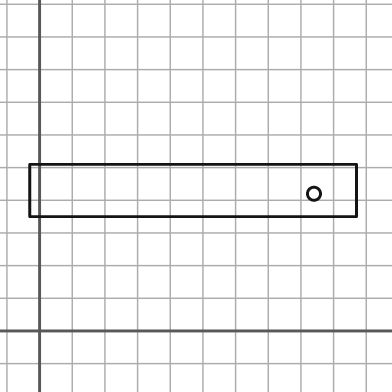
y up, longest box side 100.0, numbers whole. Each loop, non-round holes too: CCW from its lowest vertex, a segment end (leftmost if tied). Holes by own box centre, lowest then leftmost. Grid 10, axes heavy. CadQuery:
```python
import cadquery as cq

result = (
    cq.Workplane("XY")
    .moveTo(-3.0, 35.0)
    .lineTo(97.0, 35.0)
    .lineTo(97.0, 51.0)
    .lineTo(-3.0, 51.0)
    .close()
    .moveTo(84.0, 42.0)
    .circle(2.0)
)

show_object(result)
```